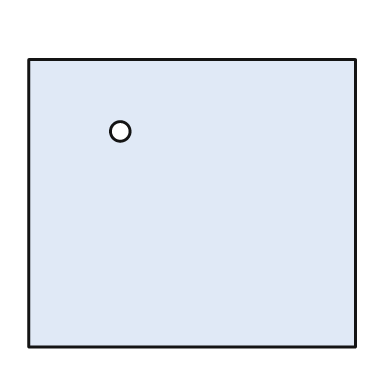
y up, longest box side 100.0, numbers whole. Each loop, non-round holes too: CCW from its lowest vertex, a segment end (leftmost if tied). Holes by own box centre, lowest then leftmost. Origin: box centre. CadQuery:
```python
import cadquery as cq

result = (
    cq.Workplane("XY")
    .moveTo(-50.0, -44.0)
    .lineTo(50.0, -44.0)
    .lineTo(50.0, 44.0)
    .lineTo(-50.0, 44.0)
    .close()
    .moveTo(-22.0, 22.0)
    .circle(3.0)
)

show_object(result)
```